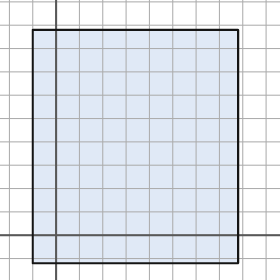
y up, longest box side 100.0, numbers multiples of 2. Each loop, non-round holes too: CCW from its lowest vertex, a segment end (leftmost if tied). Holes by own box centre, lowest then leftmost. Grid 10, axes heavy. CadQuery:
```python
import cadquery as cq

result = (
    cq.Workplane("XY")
    .moveTo(-10.0, -12.0)
    .lineTo(78.0, -12.0)
    .lineTo(78.0, 88.0)
    .lineTo(-10.0, 88.0)
    .close()
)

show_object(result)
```